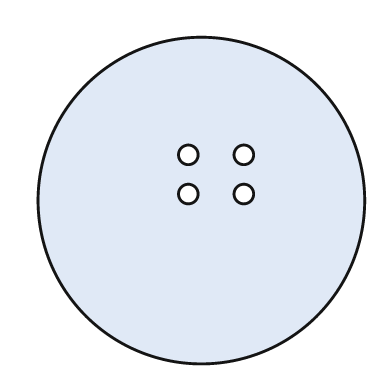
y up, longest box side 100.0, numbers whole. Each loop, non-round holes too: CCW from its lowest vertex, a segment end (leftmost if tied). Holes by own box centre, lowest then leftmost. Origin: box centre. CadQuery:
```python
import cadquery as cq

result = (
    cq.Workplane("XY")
    .moveTo(0.0, 0.0)
    .circle(50.0)
    .moveTo(-4.0, 2.0)
    .circle(3.0)
    .moveTo(13.0, 2.0)
    .circle(3.0)
    .moveTo(-4.0, 14.0)
    .circle(3.0)
    .moveTo(13.0, 14.0)
    .circle(3.0)
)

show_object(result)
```